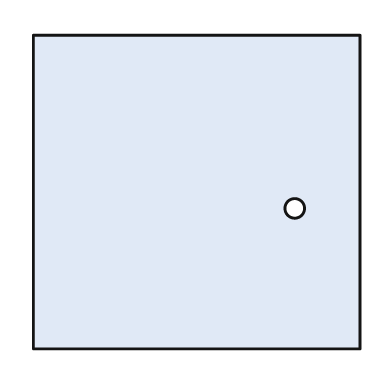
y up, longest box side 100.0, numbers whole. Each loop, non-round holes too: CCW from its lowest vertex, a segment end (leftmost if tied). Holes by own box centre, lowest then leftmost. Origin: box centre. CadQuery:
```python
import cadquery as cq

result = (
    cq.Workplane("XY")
    .moveTo(-50.0, -48.0)
    .lineTo(50.0, -48.0)
    .lineTo(50.0, 48.0)
    .lineTo(-50.0, 48.0)
    .close()
    .moveTo(30.0, -5.0)
    .circle(3.0)
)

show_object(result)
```